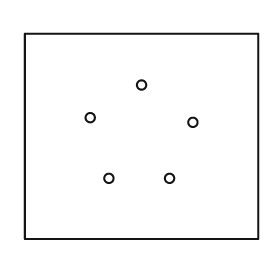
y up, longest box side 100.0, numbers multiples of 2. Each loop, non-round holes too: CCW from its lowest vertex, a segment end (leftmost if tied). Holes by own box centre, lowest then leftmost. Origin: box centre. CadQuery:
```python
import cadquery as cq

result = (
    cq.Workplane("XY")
    .moveTo(-50.0, -44.0)
    .lineTo(50.0, -44.0)
    .lineTo(50.0, 44.0)
    .lineTo(-50.0, 44.0)
    .close()
    .moveTo(-14.0, -18.0)
    .circle(2.0)
    .moveTo(12.0, -18.0)
    .circle(2.0)
    .moveTo(22.0, 6.0)
    .circle(2.0)
    .moveTo(-22.0, 8.0)
    .circle(2.0)
    .moveTo(0.0, 22.0)
    .circle(2.0)
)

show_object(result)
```